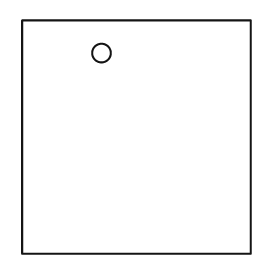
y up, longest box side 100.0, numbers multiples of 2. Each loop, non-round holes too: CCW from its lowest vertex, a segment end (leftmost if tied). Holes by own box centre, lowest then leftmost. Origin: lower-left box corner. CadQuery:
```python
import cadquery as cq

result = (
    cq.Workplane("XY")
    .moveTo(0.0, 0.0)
    .lineTo(98.0, 0.0)
    .lineTo(98.0, 100.0)
    .lineTo(0.0, 100.0)
    .close()
    .moveTo(34.0, 86.0)
    .circle(4.0)
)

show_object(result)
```